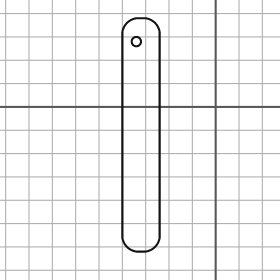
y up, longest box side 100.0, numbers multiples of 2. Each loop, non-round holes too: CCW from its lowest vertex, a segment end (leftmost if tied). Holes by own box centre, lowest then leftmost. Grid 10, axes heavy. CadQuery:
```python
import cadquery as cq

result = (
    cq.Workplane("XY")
    .moveTo(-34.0, -62.0)
    .lineTo(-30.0, -62.0)
    .threePointArc((-26.0, -60.0), (-24.0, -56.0))
    .lineTo(-24.0, 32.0)
    .threePointArc((-26.0, 36.0), (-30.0, 38.0))
    .lineTo(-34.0, 38.0)
    .threePointArc((-38.0, 36.0), (-40.0, 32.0))
    .lineTo(-40.0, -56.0)
    .threePointArc((-38.0, -60.0), (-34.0, -62.0))
    .close()
    .moveTo(-34.0, 28.0)
    .circle(2.0)
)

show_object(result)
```